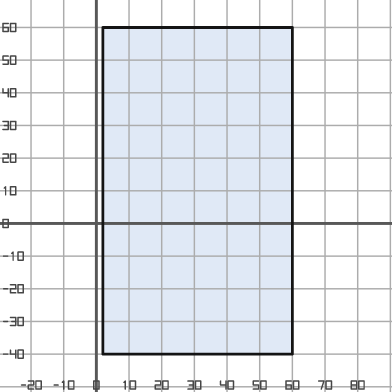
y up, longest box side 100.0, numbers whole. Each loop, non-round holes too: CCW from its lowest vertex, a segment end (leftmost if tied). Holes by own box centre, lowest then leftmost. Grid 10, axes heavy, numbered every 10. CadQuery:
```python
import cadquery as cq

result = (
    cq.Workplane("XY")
    .moveTo(2.0, -40.0)
    .lineTo(60.0, -40.0)
    .lineTo(60.0, 60.0)
    .lineTo(2.0, 60.0)
    .close()
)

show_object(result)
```